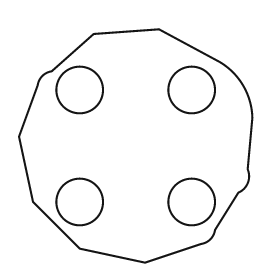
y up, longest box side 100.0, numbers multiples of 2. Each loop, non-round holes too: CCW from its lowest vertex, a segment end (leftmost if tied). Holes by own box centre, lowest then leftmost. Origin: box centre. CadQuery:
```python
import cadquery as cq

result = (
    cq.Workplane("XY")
    .moveTo(4.0, -50.0)
    .lineTo(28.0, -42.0)
    .threePointArc((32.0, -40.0), (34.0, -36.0))
    .lineTo(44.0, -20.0)
    .threePointArc((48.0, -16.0), (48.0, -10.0))
    .lineTo(50.0, 12.0)
    .threePointArc((46.0, 26.0), (36.0, 36.0))
    .lineTo(10.0, 50.0)
    .lineTo(-18.0, 48.0)
    .lineTo(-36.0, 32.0)
    .threePointArc((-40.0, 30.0), (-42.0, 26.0))
    .lineTo(-50.0, 4.0)
    .lineTo(-44.0, -24.0)
    .lineTo(-24.0, -44.0)
    .close()
    .moveTo(-24.0, -24.0)
    .circle(10.0)
    .moveTo(24.0, -24.0)
    .circle(10.0)
    .moveTo(-24.0, 24.0)
    .circle(10.0)
    .moveTo(24.0, 24.0)
    .circle(10.0)
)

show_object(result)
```